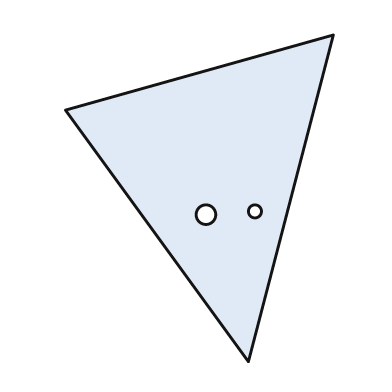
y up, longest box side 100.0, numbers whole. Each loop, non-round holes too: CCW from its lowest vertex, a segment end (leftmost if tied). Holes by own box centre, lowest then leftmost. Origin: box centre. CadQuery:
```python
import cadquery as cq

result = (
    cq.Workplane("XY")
    .moveTo(15.0, -50.0)
    .lineTo(41.0, 50.0)
    .lineTo(-41.0, 27.0)
    .close()
    .moveTo(2.0, -5.0)
    .circle(3.0)
    .moveTo(17.0, -4.0)
    .circle(2.0)
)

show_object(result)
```